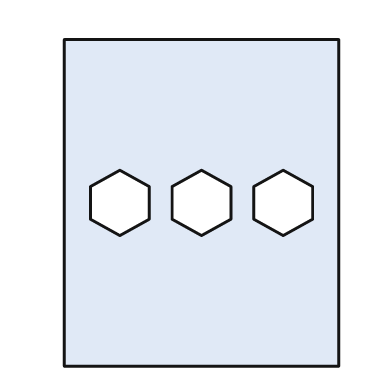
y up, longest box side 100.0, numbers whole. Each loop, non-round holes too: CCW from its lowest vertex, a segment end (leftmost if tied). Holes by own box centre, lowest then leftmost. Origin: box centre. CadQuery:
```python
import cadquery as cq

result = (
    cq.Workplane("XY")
    .moveTo(-42.0, -50.0)
    .lineTo(42.0, -50.0)
    .lineTo(42.0, 50.0)
    .lineTo(-42.0, 50.0)
    .close()
    .moveTo(-25.0, -10.0)
    .lineTo(-16.0, -5.0)
    .lineTo(-16.0, 5.0)
    .lineTo(-25.0, 10.0)
    .lineTo(-34.0, 5.0)
    .lineTo(-34.0, -5.0)
    .close()
    .moveTo(0.0, -10.0)
    .lineTo(9.0, -5.0)
    .lineTo(9.0, 5.0)
    .lineTo(0.0, 10.0)
    .lineTo(-9.0, 5.0)
    .lineTo(-9.0, -5.0)
    .close()
    .moveTo(25.0, -10.0)
    .lineTo(34.0, -5.0)
    .lineTo(34.0, 5.0)
    .lineTo(25.0, 10.0)
    .lineTo(16.0, 5.0)
    .lineTo(16.0, -5.0)
    .close()
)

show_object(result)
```